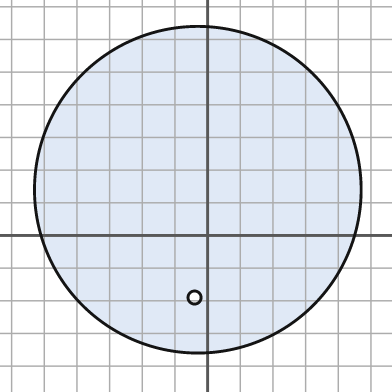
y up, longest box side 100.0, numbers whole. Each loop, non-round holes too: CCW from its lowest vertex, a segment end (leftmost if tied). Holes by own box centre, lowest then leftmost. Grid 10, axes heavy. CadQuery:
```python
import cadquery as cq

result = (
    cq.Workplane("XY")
    .moveTo(-3.0, 14.0)
    .circle(50.0)
    .moveTo(-4.0, -19.0)
    .circle(2.0)
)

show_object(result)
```